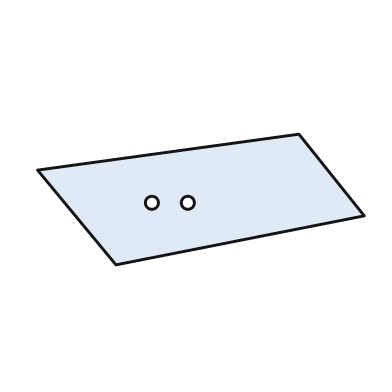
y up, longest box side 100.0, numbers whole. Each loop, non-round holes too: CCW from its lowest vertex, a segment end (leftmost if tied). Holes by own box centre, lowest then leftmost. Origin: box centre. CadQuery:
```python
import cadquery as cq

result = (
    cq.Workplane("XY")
    .moveTo(-26.0, -20.0)
    .lineTo(50.0, -5.0)
    .lineTo(30.0, 20.0)
    .lineTo(-50.0, 9.0)
    .close()
    .moveTo(-15.0, -1.0)
    .circle(2.0)
    .moveTo(-4.0, -1.0)
    .circle(2.0)
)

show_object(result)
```